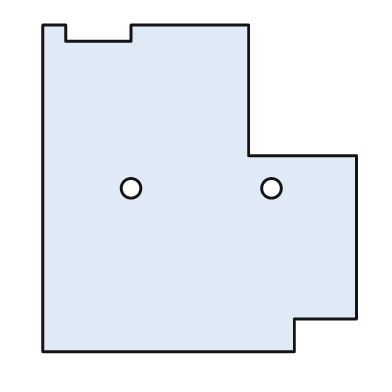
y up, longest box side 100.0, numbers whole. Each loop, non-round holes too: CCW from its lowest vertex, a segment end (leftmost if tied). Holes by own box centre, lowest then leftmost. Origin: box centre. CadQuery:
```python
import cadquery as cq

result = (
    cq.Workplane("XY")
    .moveTo(-48.0, -50.0)
    .lineTo(29.0, -50.0)
    .lineTo(29.0, -40.0)
    .lineTo(48.0, -40.0)
    .lineTo(48.0, 10.0)
    .lineTo(15.0, 10.0)
    .lineTo(15.0, 50.0)
    .lineTo(-21.0, 50.0)
    .lineTo(-21.0, 45.0)
    .lineTo(-41.0, 45.0)
    .lineTo(-41.0, 50.0)
    .lineTo(-48.0, 50.0)
    .close()
    .moveTo(-21.0, 0.0)
    .circle(3.0)
    .moveTo(22.0, 0.0)
    .circle(3.0)
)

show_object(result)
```